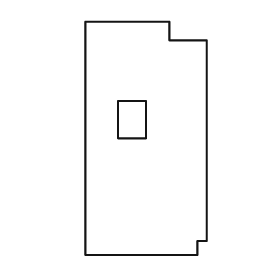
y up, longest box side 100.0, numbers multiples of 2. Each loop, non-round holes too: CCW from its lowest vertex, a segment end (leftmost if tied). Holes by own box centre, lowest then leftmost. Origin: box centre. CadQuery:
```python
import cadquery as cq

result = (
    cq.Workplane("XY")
    .moveTo(-26.0, -50.0)
    .lineTo(22.0, -50.0)
    .lineTo(22.0, -44.0)
    .lineTo(26.0, -44.0)
    .lineTo(26.0, 42.0)
    .lineTo(10.0, 42.0)
    .lineTo(10.0, 50.0)
    .lineTo(-26.0, 50.0)
    .close()
    .moveTo(-12.0, 0.0)
    .lineTo(0.0, 0.0)
    .lineTo(0.0, 16.0)
    .lineTo(-12.0, 16.0)
    .close()
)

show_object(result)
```